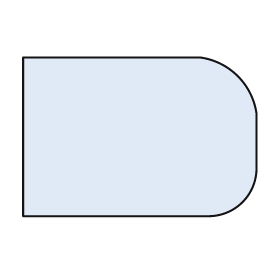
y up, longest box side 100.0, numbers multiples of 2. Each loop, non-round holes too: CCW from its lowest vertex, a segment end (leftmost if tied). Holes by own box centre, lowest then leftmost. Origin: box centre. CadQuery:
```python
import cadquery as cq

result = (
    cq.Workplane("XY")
    .moveTo(-50.0, -34.0)
    .lineTo(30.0, -34.0)
    .threePointArc((44.0, -28.0), (50.0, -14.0))
    .lineTo(50.0, 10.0)
    .threePointArc((42.0, 26.0), (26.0, 34.0))
    .lineTo(-50.0, 34.0)
    .close()
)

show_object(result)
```